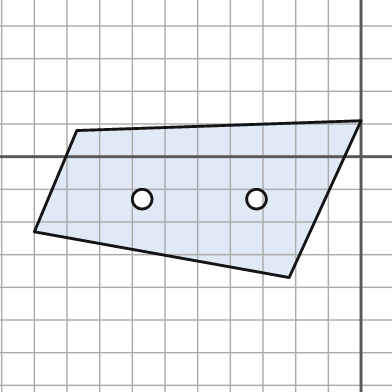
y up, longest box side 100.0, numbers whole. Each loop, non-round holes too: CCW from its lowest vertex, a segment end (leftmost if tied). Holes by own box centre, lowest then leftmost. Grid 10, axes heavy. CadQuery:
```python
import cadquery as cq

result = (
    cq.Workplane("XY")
    .moveTo(-22.0, -37.0)
    .lineTo(0.0, 11.0)
    .lineTo(-87.0, 8.0)
    .lineTo(-100.0, -23.0)
    .close()
    .moveTo(-67.0, -13.0)
    .circle(3.0)
    .moveTo(-32.0, -13.0)
    .circle(3.0)
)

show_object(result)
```